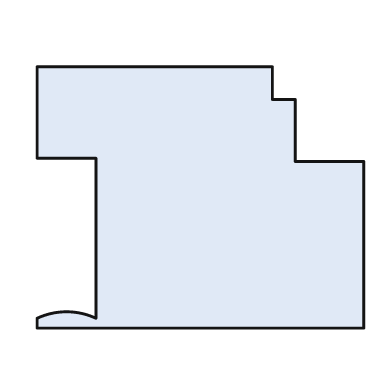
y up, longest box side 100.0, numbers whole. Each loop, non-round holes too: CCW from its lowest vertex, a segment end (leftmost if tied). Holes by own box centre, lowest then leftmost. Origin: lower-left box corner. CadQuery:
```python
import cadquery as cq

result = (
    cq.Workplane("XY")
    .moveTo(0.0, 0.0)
    .lineTo(100.0, 0.0)
    .lineTo(100.0, 51.0)
    .lineTo(79.0, 51.0)
    .lineTo(79.0, 70.0)
    .lineTo(72.0, 70.0)
    .lineTo(72.0, 80.0)
    .lineTo(0.0, 80.0)
    .lineTo(0.0, 52.0)
    .lineTo(18.0, 52.0)
    .lineTo(18.0, 3.0)
    .threePointArc((9.0, 5.0), (0.0, 3.0))
    .close()
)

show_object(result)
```